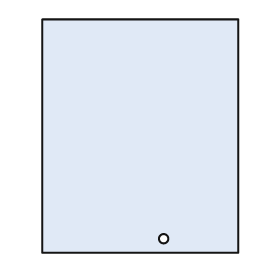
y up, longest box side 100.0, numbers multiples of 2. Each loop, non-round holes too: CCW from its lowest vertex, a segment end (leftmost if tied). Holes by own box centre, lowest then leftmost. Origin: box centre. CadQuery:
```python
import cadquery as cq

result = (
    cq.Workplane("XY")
    .moveTo(-42.0, -50.0)
    .lineTo(42.0, -50.0)
    .lineTo(42.0, 50.0)
    .lineTo(-42.0, 50.0)
    .close()
    .moveTo(10.0, -44.0)
    .circle(2.0)
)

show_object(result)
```